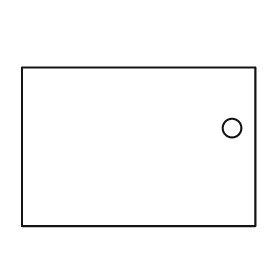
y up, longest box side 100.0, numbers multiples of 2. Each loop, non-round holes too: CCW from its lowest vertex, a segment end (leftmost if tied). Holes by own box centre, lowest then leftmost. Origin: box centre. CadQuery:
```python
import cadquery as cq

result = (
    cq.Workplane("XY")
    .moveTo(-50.0, -34.0)
    .lineTo(50.0, -34.0)
    .lineTo(50.0, 34.0)
    .lineTo(-50.0, 34.0)
    .close()
    .moveTo(40.0, 8.0)
    .circle(4.0)
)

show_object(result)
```